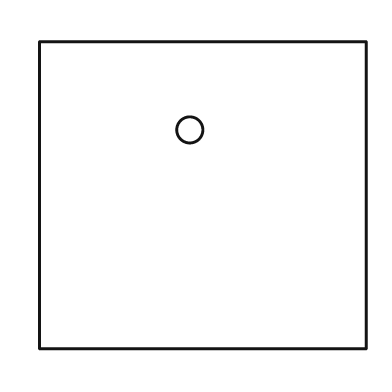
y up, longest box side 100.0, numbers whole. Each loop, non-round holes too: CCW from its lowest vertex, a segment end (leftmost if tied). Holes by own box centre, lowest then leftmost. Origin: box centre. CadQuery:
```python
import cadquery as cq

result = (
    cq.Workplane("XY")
    .moveTo(-50.0, -47.0)
    .lineTo(50.0, -47.0)
    .lineTo(50.0, 47.0)
    .lineTo(-50.0, 47.0)
    .close()
    .moveTo(-4.0, 20.0)
    .circle(4.0)
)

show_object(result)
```